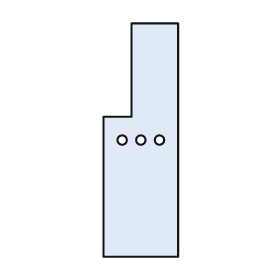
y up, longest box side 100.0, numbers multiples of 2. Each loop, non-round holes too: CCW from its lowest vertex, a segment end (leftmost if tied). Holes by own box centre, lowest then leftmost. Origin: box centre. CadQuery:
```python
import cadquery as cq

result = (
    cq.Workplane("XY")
    .moveTo(-16.0, -50.0)
    .lineTo(16.0, -50.0)
    .lineTo(16.0, 50.0)
    .lineTo(-4.0, 50.0)
    .lineTo(-4.0, 10.0)
    .lineTo(-16.0, 10.0)
    .close()
    .moveTo(-8.0, 0.0)
    .circle(2.0)
    .moveTo(0.0, 0.0)
    .circle(2.0)
    .moveTo(8.0, 0.0)
    .circle(2.0)
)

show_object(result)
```